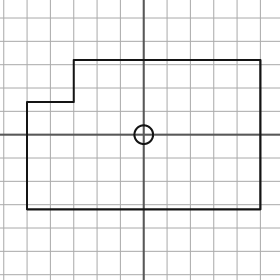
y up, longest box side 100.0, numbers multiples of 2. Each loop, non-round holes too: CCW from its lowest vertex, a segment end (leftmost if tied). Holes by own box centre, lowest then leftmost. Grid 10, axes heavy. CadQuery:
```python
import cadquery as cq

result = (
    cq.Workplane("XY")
    .moveTo(-50.0, -32.0)
    .lineTo(50.0, -32.0)
    .lineTo(50.0, 32.0)
    .lineTo(-30.0, 32.0)
    .lineTo(-30.0, 14.0)
    .lineTo(-50.0, 14.0)
    .close()
    .moveTo(0.0, 0.0)
    .circle(4.0)
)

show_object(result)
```